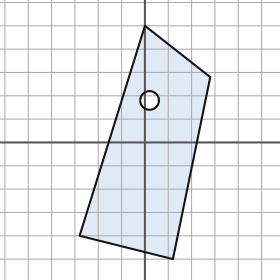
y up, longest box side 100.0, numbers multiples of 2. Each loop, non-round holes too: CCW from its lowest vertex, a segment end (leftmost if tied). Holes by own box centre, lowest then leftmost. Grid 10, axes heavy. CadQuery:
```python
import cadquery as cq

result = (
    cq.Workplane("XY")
    .moveTo(12.0, -50.0)
    .lineTo(28.0, 28.0)
    .lineTo(0.0, 50.0)
    .lineTo(-28.0, -40.0)
    .close()
    .moveTo(2.0, 18.0)
    .circle(4.0)
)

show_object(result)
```